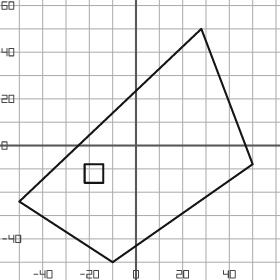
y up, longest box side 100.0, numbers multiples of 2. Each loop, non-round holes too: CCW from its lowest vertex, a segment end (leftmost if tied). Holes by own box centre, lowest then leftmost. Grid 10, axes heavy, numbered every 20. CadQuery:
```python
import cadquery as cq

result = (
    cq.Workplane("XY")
    .moveTo(-10.0, -50.0)
    .lineTo(50.0, -8.0)
    .lineTo(28.0, 50.0)
    .lineTo(-50.0, -24.0)
    .close()
    .moveTo(-22.0, -16.0)
    .lineTo(-14.0, -16.0)
    .lineTo(-14.0, -8.0)
    .lineTo(-22.0, -8.0)
    .close()
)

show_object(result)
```